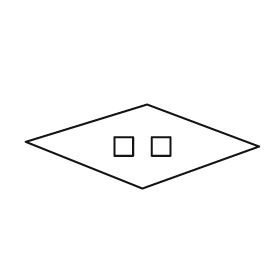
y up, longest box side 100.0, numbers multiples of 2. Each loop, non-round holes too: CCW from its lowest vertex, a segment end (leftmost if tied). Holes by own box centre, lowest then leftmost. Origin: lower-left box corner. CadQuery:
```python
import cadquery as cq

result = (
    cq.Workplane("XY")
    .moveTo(50.0, 0.0)
    .lineTo(100.0, 18.0)
    .lineTo(52.0, 36.0)
    .lineTo(0.0, 20.0)
    .close()
    .moveTo(38.0, 14.0)
    .lineTo(46.0, 14.0)
    .lineTo(46.0, 22.0)
    .lineTo(38.0, 22.0)
    .close()
    .moveTo(54.0, 14.0)
    .lineTo(62.0, 14.0)
    .lineTo(62.0, 22.0)
    .lineTo(54.0, 22.0)
    .close()
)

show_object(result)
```